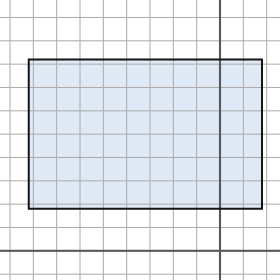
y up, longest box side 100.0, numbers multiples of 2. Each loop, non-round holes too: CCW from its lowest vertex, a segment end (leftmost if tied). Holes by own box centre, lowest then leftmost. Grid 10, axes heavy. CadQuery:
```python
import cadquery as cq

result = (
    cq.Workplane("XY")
    .moveTo(-82.0, 18.0)
    .lineTo(18.0, 18.0)
    .lineTo(18.0, 82.0)
    .lineTo(-82.0, 82.0)
    .close()
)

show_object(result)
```